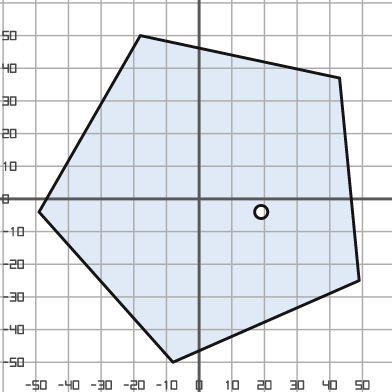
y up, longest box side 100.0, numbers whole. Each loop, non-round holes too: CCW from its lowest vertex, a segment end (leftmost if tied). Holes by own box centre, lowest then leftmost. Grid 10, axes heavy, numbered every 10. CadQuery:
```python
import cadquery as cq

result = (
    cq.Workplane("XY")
    .moveTo(-8.0, -50.0)
    .lineTo(49.0, -25.0)
    .lineTo(43.0, 37.0)
    .lineTo(-18.0, 50.0)
    .lineTo(-49.0, -4.0)
    .close()
    .moveTo(19.0, -4.0)
    .circle(2.0)
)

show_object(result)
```